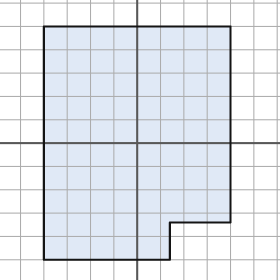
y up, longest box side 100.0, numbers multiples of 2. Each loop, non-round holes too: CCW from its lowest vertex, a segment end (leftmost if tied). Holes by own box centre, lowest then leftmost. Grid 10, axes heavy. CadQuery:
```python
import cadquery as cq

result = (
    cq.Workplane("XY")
    .moveTo(-40.0, -50.0)
    .lineTo(14.0, -50.0)
    .lineTo(14.0, -34.0)
    .lineTo(40.0, -34.0)
    .lineTo(40.0, 50.0)
    .lineTo(-40.0, 50.0)
    .close()
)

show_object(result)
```